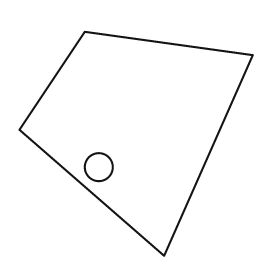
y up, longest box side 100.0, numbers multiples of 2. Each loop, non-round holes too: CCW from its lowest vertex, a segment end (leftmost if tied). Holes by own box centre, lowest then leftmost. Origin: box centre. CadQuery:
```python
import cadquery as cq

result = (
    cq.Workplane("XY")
    .moveTo(12.0, -48.0)
    .lineTo(50.0, 38.0)
    .lineTo(-22.0, 48.0)
    .lineTo(-50.0, 6.0)
    .close()
    .moveTo(-16.0, -10.0)
    .circle(6.0)
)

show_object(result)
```